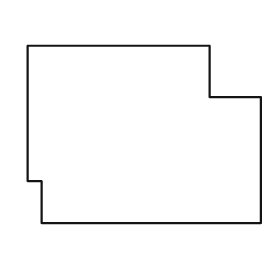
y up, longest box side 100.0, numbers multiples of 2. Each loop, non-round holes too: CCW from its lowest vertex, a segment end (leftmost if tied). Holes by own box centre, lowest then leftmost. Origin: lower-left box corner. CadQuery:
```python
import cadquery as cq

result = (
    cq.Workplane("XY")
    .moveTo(6.0, 0.0)
    .lineTo(100.0, 0.0)
    .lineTo(100.0, 54.0)
    .lineTo(78.0, 54.0)
    .lineTo(78.0, 76.0)
    .lineTo(0.0, 76.0)
    .lineTo(0.0, 18.0)
    .lineTo(6.0, 18.0)
    .close()
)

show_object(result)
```